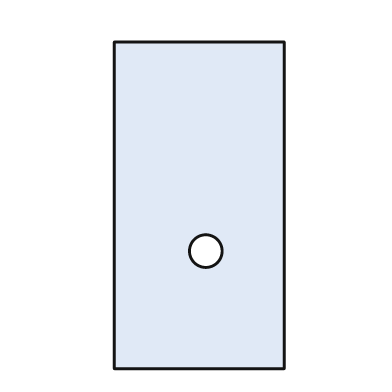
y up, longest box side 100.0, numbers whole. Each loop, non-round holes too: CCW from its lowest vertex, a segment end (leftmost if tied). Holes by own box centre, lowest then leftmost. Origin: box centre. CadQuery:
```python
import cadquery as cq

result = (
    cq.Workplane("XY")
    .moveTo(-26.0, -50.0)
    .lineTo(26.0, -50.0)
    .lineTo(26.0, 50.0)
    .lineTo(-26.0, 50.0)
    .close()
    .moveTo(2.0, -14.0)
    .circle(5.0)
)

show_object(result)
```